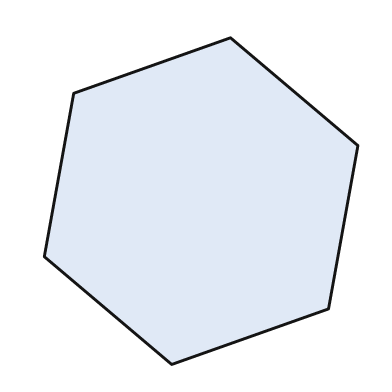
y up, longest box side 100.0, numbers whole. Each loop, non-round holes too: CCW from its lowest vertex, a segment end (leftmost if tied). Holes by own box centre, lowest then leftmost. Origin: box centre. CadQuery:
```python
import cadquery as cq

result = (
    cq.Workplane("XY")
    .moveTo(-9.0, -50.0)
    .lineTo(39.0, -33.0)
    .lineTo(48.0, 17.0)
    .lineTo(9.0, 50.0)
    .lineTo(-39.0, 33.0)
    .lineTo(-48.0, -17.0)
    .close()
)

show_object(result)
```